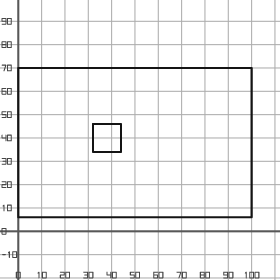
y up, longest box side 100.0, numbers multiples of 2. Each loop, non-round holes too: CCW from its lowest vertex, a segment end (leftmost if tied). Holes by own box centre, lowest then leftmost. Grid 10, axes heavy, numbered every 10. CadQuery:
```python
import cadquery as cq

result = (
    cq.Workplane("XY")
    .moveTo(0.0, 6.0)
    .lineTo(100.0, 6.0)
    .lineTo(100.0, 70.0)
    .lineTo(0.0, 70.0)
    .close()
    .moveTo(32.0, 34.0)
    .lineTo(44.0, 34.0)
    .lineTo(44.0, 46.0)
    .lineTo(32.0, 46.0)
    .close()
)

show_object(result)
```